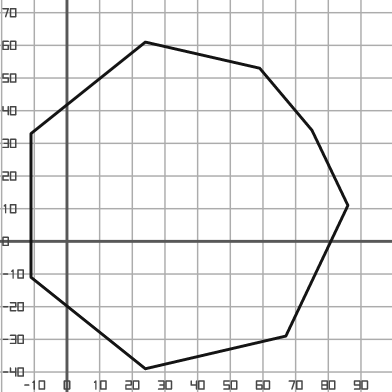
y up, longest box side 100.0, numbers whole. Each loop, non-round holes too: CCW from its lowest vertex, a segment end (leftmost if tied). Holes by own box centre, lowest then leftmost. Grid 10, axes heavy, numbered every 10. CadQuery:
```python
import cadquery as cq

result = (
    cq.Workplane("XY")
    .moveTo(24.0, -39.0)
    .lineTo(67.0, -29.0)
    .lineTo(86.0, 11.0)
    .lineTo(75.0, 34.0)
    .lineTo(59.0, 53.0)
    .lineTo(24.0, 61.0)
    .lineTo(-11.0, 33.0)
    .lineTo(-11.0, -11.0)
    .close()
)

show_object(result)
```